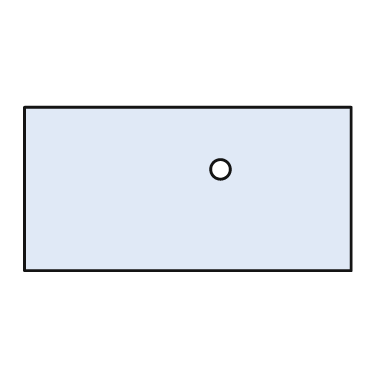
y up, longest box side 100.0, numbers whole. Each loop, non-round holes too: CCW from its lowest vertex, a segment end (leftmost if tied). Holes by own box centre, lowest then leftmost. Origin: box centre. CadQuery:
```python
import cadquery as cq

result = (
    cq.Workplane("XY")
    .moveTo(-50.0, -25.0)
    .lineTo(50.0, -25.0)
    .lineTo(50.0, 25.0)
    .lineTo(-50.0, 25.0)
    .close()
    .moveTo(10.0, 6.0)
    .circle(3.0)
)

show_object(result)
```